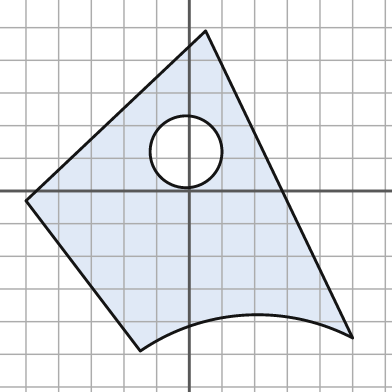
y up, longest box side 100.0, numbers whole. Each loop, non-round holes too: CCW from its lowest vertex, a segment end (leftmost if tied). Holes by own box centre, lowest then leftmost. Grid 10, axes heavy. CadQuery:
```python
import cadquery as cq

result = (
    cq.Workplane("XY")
    .moveTo(-15.0, -49.0)
    .threePointArc((17.0, -38.0), (50.0, -45.0))
    .lineTo(5.0, 49.0)
    .lineTo(-50.0, -3.0)
    .close()
    .moveTo(-1.0, 12.0)
    .circle(11.0)
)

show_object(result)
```